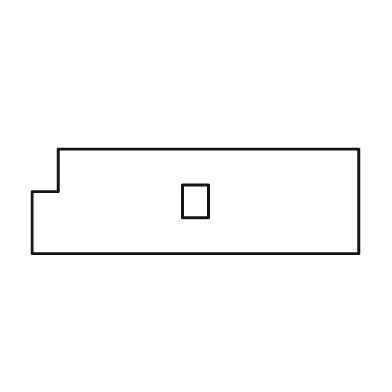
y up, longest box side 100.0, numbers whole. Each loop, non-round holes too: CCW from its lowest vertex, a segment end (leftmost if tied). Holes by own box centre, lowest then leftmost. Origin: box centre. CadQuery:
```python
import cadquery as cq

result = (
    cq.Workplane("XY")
    .moveTo(-50.0, -16.0)
    .lineTo(50.0, -16.0)
    .lineTo(50.0, 16.0)
    .lineTo(-42.0, 16.0)
    .lineTo(-42.0, 3.0)
    .lineTo(-50.0, 3.0)
    .close()
    .moveTo(-4.0, -5.0)
    .lineTo(4.0, -5.0)
    .lineTo(4.0, 5.0)
    .lineTo(-4.0, 5.0)
    .close()
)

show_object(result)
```